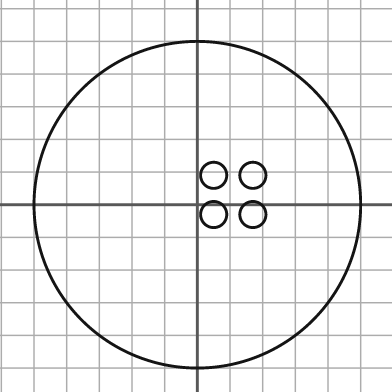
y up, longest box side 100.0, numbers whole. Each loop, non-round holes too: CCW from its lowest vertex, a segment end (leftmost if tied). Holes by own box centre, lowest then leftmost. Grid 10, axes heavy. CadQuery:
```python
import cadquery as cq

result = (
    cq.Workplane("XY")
    .moveTo(0.0, 0.0)
    .circle(50.0)
    .moveTo(5.0, -3.0)
    .circle(4.0)
    .moveTo(17.0, -3.0)
    .circle(4.0)
    .moveTo(5.0, 9.0)
    .circle(4.0)
    .moveTo(17.0, 9.0)
    .circle(4.0)
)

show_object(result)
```